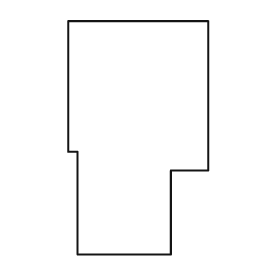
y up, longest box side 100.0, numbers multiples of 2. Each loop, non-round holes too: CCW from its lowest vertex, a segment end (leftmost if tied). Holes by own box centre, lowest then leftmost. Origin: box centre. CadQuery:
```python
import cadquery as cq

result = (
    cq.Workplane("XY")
    .moveTo(-26.0, -50.0)
    .lineTo(14.0, -50.0)
    .lineTo(14.0, -14.0)
    .lineTo(30.0, -14.0)
    .lineTo(30.0, 50.0)
    .lineTo(-30.0, 50.0)
    .lineTo(-30.0, -6.0)
    .lineTo(-26.0, -6.0)
    .close()
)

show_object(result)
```